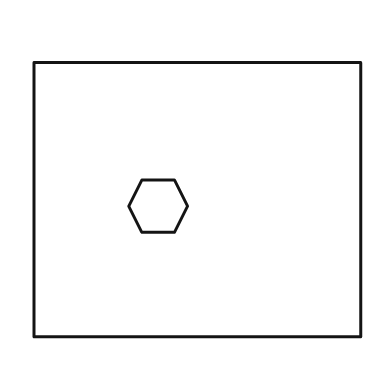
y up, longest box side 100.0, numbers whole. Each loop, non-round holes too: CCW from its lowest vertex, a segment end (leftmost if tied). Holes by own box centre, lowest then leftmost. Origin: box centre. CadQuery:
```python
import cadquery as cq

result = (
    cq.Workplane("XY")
    .moveTo(-50.0, -42.0)
    .lineTo(50.0, -42.0)
    .lineTo(50.0, 42.0)
    .lineTo(-50.0, 42.0)
    .close()
    .moveTo(-17.0, -10.0)
    .lineTo(-7.0, -10.0)
    .lineTo(-3.0, -2.0)
    .lineTo(-7.0, 6.0)
    .lineTo(-17.0, 6.0)
    .lineTo(-21.0, -2.0)
    .close()
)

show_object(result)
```